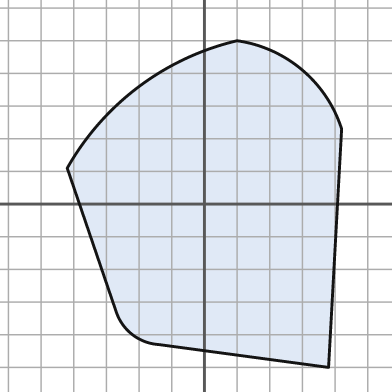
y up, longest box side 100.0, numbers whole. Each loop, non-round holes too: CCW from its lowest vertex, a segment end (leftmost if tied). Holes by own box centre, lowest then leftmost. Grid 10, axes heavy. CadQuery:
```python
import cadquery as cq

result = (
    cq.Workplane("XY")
    .moveTo(38.0, -50.0)
    .lineTo(42.0, 23.0)
    .threePointArc((30.0, 41.0), (10.0, 50.0))
    .threePointArc((-20.0, 36.0), (-42.0, 11.0))
    .lineTo(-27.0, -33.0)
    .threePointArc((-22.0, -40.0), (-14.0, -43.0))
    .close()
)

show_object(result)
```